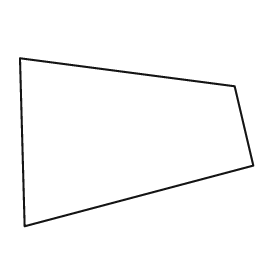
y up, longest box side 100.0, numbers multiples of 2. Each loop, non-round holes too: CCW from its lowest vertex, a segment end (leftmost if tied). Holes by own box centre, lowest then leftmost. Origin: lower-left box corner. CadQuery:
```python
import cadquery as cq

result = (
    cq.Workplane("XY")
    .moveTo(2.0, 0.0)
    .lineTo(100.0, 26.0)
    .lineTo(92.0, 60.0)
    .lineTo(0.0, 72.0)
    .close()
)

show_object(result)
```